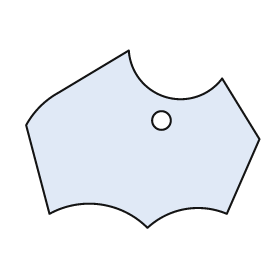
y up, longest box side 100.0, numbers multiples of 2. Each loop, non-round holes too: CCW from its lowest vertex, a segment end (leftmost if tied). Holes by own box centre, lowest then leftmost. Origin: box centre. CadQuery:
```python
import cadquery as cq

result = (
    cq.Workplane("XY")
    .moveTo(2.0, -38.0)
    .threePointArc((18.0, -30.0), (36.0, -32.0))
    .lineTo(50.0, 0.0)
    .lineTo(34.0, 26.0)
    .threePointArc((10.0, 18.0), (-6.0, 38.0))
    .lineTo(-36.0, 20.0)
    .threePointArc((-44.0, 14.0), (-50.0, 6.0))
    .lineTo(-40.0, -32.0)
    .threePointArc((-18.0, -28.0), (2.0, -38.0))
    .close()
    .moveTo(8.0, 8.0)
    .circle(4.0)
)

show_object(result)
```